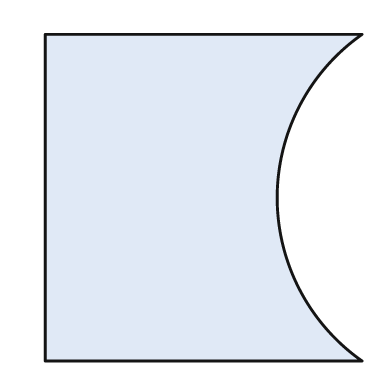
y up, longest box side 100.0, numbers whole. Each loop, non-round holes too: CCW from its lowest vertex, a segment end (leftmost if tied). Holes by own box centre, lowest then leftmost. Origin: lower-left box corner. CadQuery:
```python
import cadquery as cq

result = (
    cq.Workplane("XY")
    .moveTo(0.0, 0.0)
    .lineTo(97.0, 0.0)
    .threePointArc((71.0, 50.0), (97.0, 100.0))
    .lineTo(0.0, 100.0)
    .close()
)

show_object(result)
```